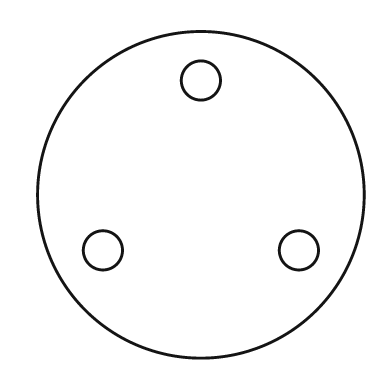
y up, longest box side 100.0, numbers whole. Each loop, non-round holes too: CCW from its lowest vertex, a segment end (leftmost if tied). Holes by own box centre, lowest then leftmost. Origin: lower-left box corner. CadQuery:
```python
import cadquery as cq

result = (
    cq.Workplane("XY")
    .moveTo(50.0, 50.0)
    .circle(50.0)
    .moveTo(20.0, 33.0)
    .circle(6.0)
    .moveTo(80.0, 33.0)
    .circle(6.0)
    .moveTo(50.0, 85.0)
    .circle(6.0)
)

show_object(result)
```